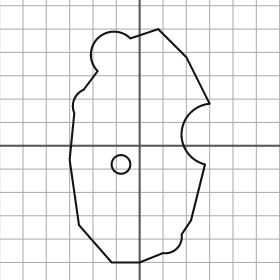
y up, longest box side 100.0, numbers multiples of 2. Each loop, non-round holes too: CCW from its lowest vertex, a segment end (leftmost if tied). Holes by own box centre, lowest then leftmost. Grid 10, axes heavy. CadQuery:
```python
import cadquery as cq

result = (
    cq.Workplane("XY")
    .moveTo(-12.0, -50.0)
    .lineTo(0.0, -50.0)
    .lineTo(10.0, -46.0)
    .threePointArc((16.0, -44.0), (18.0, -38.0))
    .lineTo(22.0, -32.0)
    .lineTo(28.0, -8.0)
    .threePointArc((18.0, 6.0), (30.0, 18.0))
    .lineTo(20.0, 38.0)
    .lineTo(8.0, 50.0)
    .lineTo(-4.0, 46.0)
    .threePointArc((-18.0, 46.0), (-18.0, 32.0))
    .lineTo(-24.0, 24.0)
    .threePointArc((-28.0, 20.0), (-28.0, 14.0))
    .lineTo(-30.0, -6.0)
    .lineTo(-26.0, -34.0)
    .close()
    .moveTo(-8.0, -8.0)
    .circle(4.0)
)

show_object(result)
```